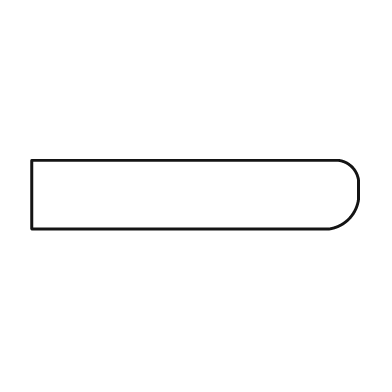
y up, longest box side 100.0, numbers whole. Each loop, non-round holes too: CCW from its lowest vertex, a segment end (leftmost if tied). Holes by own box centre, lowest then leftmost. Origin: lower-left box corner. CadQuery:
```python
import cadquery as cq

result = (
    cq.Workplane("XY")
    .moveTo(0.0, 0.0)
    .lineTo(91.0, 0.0)
    .threePointArc((97.0, 3.0), (100.0, 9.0))
    .lineTo(100.0, 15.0)
    .threePointArc((98.0, 19.0), (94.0, 21.0))
    .lineTo(0.0, 21.0)
    .close()
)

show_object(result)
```